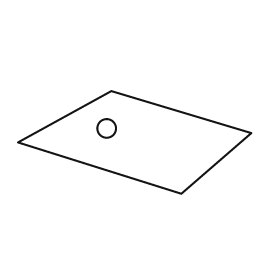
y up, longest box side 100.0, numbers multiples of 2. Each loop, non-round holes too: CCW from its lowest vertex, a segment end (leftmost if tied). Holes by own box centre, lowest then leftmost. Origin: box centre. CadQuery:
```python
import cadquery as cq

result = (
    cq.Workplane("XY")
    .moveTo(20.0, -22.0)
    .lineTo(50.0, 4.0)
    .lineTo(-10.0, 22.0)
    .lineTo(-50.0, 0.0)
    .close()
    .moveTo(-12.0, 6.0)
    .circle(4.0)
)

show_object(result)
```